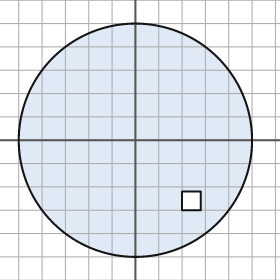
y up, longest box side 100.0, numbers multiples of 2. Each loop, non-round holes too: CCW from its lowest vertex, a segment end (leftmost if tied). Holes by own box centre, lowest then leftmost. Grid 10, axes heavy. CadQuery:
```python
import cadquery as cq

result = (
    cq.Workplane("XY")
    .moveTo(0.0, 0.0)
    .circle(50.0)
    .moveTo(20.0, -30.0)
    .lineTo(28.0, -30.0)
    .lineTo(28.0, -22.0)
    .lineTo(20.0, -22.0)
    .close()
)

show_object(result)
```